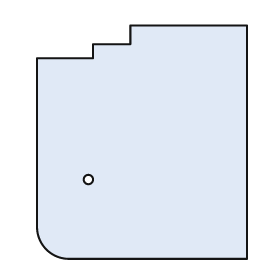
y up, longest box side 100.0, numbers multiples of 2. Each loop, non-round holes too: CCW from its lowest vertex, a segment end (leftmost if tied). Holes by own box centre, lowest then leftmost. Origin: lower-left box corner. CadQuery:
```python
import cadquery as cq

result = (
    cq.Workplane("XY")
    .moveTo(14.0, 0.0)
    .lineTo(90.0, 0.0)
    .lineTo(90.0, 100.0)
    .lineTo(40.0, 100.0)
    .lineTo(40.0, 92.0)
    .lineTo(24.0, 92.0)
    .lineTo(24.0, 86.0)
    .lineTo(0.0, 86.0)
    .lineTo(0.0, 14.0)
    .threePointArc((4.0, 4.0), (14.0, 0.0))
    .close()
    .moveTo(22.0, 34.0)
    .circle(2.0)
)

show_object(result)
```